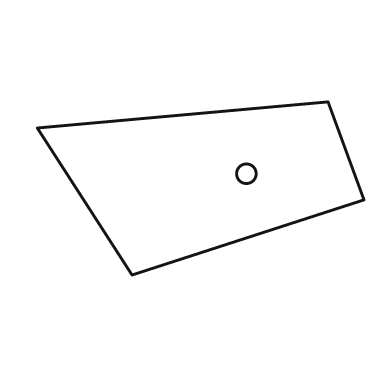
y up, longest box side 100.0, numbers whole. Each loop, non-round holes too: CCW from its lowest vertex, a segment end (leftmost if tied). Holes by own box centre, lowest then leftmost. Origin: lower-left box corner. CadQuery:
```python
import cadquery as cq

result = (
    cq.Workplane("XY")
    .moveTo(29.0, 0.0)
    .lineTo(100.0, 23.0)
    .lineTo(89.0, 53.0)
    .lineTo(0.0, 45.0)
    .close()
    .moveTo(64.0, 31.0)
    .circle(3.0)
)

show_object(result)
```